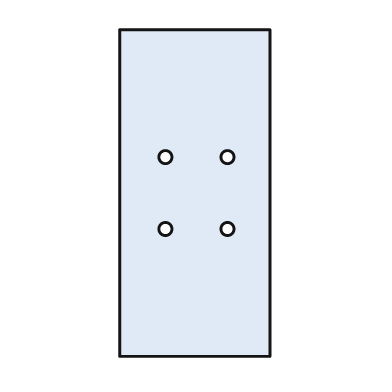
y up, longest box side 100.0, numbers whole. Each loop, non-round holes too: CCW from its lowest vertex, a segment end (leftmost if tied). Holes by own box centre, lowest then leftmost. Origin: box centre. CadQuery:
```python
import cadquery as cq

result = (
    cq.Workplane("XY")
    .moveTo(-23.0, -50.0)
    .lineTo(23.0, -50.0)
    .lineTo(23.0, 50.0)
    .lineTo(-23.0, 50.0)
    .close()
    .moveTo(-9.0, -11.0)
    .circle(2.0)
    .moveTo(10.0, -11.0)
    .circle(2.0)
    .moveTo(-9.0, 11.0)
    .circle(2.0)
    .moveTo(10.0, 11.0)
    .circle(2.0)
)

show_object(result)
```